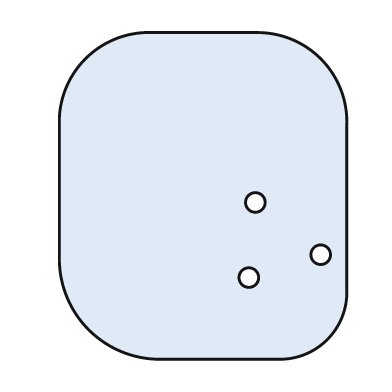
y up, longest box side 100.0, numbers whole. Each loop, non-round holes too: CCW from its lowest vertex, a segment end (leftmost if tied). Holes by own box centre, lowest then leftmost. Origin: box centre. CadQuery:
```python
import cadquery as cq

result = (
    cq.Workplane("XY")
    .moveTo(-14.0, -50.0)
    .lineTo(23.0, -50.0)
    .threePointArc((38.0, -44.0), (44.0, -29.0))
    .lineTo(44.0, 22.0)
    .threePointArc((36.0, 42.0), (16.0, 50.0))
    .lineTo(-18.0, 50.0)
    .threePointArc((-36.0, 42.0), (-44.0, 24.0))
    .lineTo(-44.0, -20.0)
    .threePointArc((-35.0, -41.0), (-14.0, -50.0))
    .close()
    .moveTo(14.0, -25.0)
    .circle(3.0)
    .moveTo(36.0, -18.0)
    .circle(3.0)
    .moveTo(16.0, -2.0)
    .circle(3.0)
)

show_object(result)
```